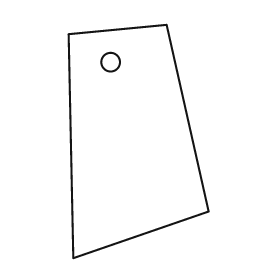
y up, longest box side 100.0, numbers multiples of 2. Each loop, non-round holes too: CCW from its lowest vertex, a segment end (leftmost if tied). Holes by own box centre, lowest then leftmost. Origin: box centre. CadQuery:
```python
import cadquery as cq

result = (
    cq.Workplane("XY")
    .moveTo(-28.0, -50.0)
    .lineTo(30.0, -30.0)
    .lineTo(12.0, 50.0)
    .lineTo(-30.0, 46.0)
    .close()
    .moveTo(-12.0, 34.0)
    .circle(4.0)
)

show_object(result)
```